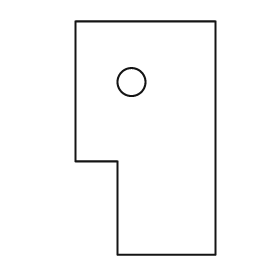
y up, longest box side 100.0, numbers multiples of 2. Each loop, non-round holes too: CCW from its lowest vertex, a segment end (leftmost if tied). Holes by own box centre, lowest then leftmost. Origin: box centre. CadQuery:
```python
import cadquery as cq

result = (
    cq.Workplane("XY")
    .moveTo(-12.0, -50.0)
    .lineTo(30.0, -50.0)
    .lineTo(30.0, 50.0)
    .lineTo(-30.0, 50.0)
    .lineTo(-30.0, -10.0)
    .lineTo(-12.0, -10.0)
    .close()
    .moveTo(-6.0, 24.0)
    .circle(6.0)
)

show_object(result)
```